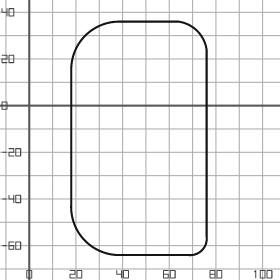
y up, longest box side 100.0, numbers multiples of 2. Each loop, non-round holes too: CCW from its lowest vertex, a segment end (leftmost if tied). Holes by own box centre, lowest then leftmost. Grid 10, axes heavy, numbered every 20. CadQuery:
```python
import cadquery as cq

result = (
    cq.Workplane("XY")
    .moveTo(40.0, -64.0)
    .lineTo(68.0, -64.0)
    .threePointArc((74.0, -62.0), (76.0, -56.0))
    .lineTo(76.0, 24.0)
    .threePointArc((72.0, 32.0), (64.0, 36.0))
    .lineTo(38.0, 36.0)
    .threePointArc((24.0, 30.0), (18.0, 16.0))
    .lineTo(18.0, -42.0)
    .threePointArc((24.0, -58.0), (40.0, -64.0))
    .close()
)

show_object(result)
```